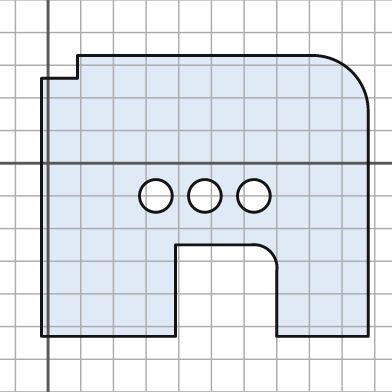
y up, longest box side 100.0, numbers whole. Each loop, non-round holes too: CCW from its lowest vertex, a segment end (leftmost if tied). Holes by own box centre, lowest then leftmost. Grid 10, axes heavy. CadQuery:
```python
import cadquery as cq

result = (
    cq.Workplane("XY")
    .moveTo(-2.0, -53.0)
    .lineTo(39.0, -53.0)
    .lineTo(39.0, -25.0)
    .lineTo(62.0, -25.0)
    .threePointArc((68.0, -27.0), (70.0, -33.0))
    .lineTo(70.0, -53.0)
    .lineTo(98.0, -53.0)
    .lineTo(98.0, 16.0)
    .threePointArc((93.0, 28.0), (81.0, 33.0))
    .lineTo(9.0, 33.0)
    .lineTo(9.0, 26.0)
    .lineTo(-2.0, 26.0)
    .close()
    .moveTo(33.0, -10.0)
    .circle(5.0)
    .moveTo(48.0, -10.0)
    .circle(5.0)
    .moveTo(63.0, -10.0)
    .circle(5.0)
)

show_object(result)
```